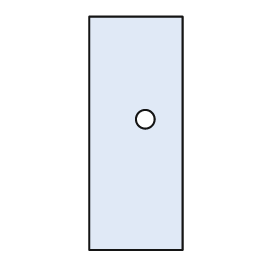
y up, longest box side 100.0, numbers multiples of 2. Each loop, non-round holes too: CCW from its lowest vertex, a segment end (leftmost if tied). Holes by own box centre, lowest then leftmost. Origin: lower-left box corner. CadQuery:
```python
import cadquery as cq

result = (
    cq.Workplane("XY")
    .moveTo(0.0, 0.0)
    .lineTo(40.0, 0.0)
    .lineTo(40.0, 100.0)
    .lineTo(0.0, 100.0)
    .close()
    .moveTo(24.0, 56.0)
    .circle(4.0)
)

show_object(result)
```